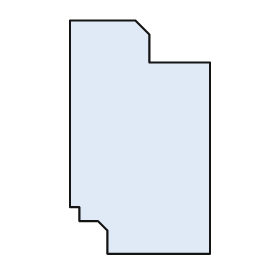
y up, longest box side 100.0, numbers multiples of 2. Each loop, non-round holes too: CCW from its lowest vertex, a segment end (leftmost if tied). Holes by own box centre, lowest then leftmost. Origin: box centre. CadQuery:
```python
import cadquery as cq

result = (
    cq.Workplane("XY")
    .moveTo(-14.0, -50.0)
    .lineTo(30.0, -50.0)
    .lineTo(30.0, 32.0)
    .lineTo(4.0, 32.0)
    .lineTo(4.0, 44.0)
    .lineTo(-2.0, 50.0)
    .lineTo(-30.0, 50.0)
    .lineTo(-30.0, -30.0)
    .lineTo(-26.0, -30.0)
    .lineTo(-26.0, -36.0)
    .lineTo(-18.0, -36.0)
    .lineTo(-14.0, -40.0)
    .close()
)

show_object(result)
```